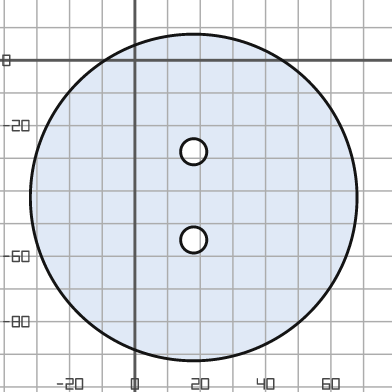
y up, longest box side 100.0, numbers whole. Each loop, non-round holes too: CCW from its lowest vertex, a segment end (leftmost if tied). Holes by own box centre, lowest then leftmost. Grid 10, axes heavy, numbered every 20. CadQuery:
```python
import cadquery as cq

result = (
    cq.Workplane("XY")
    .moveTo(18.0, -42.0)
    .circle(50.0)
    .moveTo(18.0, -55.0)
    .circle(4.0)
    .moveTo(18.0, -28.0)
    .circle(4.0)
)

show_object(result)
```